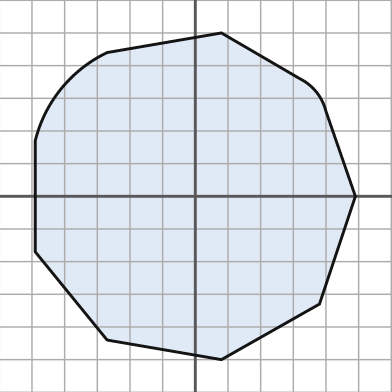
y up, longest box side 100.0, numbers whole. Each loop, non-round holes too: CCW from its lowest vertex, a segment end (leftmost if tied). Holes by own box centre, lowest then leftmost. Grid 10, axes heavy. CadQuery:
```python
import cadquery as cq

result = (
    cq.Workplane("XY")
    .moveTo(8.0, -50.0)
    .lineTo(38.0, -33.0)
    .lineTo(49.0, 0.0)
    .lineTo(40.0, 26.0)
    .threePointArc((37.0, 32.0), (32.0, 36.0))
    .lineTo(8.0, 50.0)
    .lineTo(-27.0, 44.0)
    .threePointArc((-41.0, 33.0), (-49.0, 17.0))
    .lineTo(-49.0, -17.0)
    .lineTo(-27.0, -44.0)
    .close()
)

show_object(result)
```